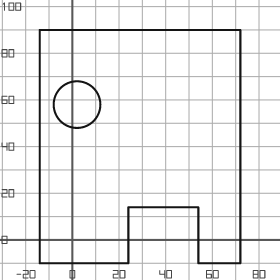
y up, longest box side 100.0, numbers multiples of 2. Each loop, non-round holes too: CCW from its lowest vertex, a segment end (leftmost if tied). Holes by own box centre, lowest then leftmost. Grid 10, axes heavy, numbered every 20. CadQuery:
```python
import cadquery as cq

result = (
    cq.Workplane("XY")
    .moveTo(-14.0, -10.0)
    .lineTo(24.0, -10.0)
    .lineTo(24.0, 14.0)
    .lineTo(54.0, 14.0)
    .lineTo(54.0, -10.0)
    .lineTo(72.0, -10.0)
    .lineTo(72.0, 90.0)
    .lineTo(-14.0, 90.0)
    .close()
    .moveTo(2.0, 58.0)
    .circle(10.0)
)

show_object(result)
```